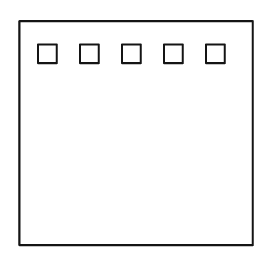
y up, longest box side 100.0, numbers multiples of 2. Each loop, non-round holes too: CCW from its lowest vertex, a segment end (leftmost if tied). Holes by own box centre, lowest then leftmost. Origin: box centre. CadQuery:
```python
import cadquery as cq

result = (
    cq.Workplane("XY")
    .moveTo(-50.0, -48.0)
    .lineTo(50.0, -48.0)
    .lineTo(50.0, 48.0)
    .lineTo(-50.0, 48.0)
    .close()
    .moveTo(-42.0, 30.0)
    .lineTo(-34.0, 30.0)
    .lineTo(-34.0, 38.0)
    .lineTo(-42.0, 38.0)
    .close()
    .moveTo(-24.0, 30.0)
    .lineTo(-16.0, 30.0)
    .lineTo(-16.0, 38.0)
    .lineTo(-24.0, 38.0)
    .close()
    .moveTo(-6.0, 30.0)
    .lineTo(2.0, 30.0)
    .lineTo(2.0, 38.0)
    .lineTo(-6.0, 38.0)
    .close()
    .moveTo(12.0, 30.0)
    .lineTo(20.0, 30.0)
    .lineTo(20.0, 38.0)
    .lineTo(12.0, 38.0)
    .close()
    .moveTo(30.0, 30.0)
    .lineTo(38.0, 30.0)
    .lineTo(38.0, 38.0)
    .lineTo(30.0, 38.0)
    .close()
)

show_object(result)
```